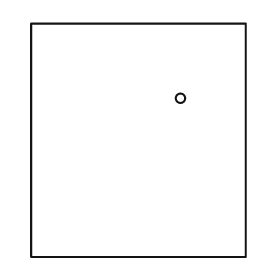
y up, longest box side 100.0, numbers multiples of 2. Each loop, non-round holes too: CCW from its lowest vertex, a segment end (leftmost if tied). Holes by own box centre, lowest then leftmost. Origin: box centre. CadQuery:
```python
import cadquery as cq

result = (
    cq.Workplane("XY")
    .moveTo(-46.0, -50.0)
    .lineTo(46.0, -50.0)
    .lineTo(46.0, 50.0)
    .lineTo(-46.0, 50.0)
    .close()
    .moveTo(18.0, 18.0)
    .circle(2.0)
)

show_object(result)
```